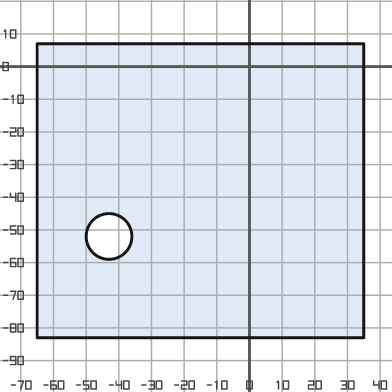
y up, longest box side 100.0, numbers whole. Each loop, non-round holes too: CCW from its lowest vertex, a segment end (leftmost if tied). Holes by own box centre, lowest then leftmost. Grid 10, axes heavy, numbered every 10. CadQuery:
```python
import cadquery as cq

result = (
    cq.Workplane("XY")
    .moveTo(-65.0, -83.0)
    .lineTo(35.0, -83.0)
    .lineTo(35.0, 7.0)
    .lineTo(-65.0, 7.0)
    .close()
    .moveTo(-43.0, -52.0)
    .circle(7.0)
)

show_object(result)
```